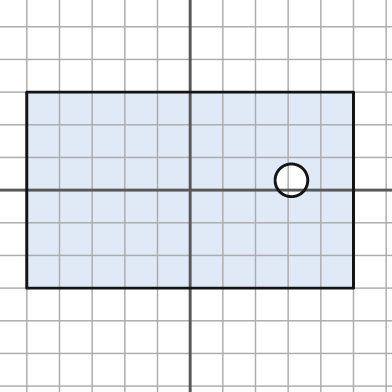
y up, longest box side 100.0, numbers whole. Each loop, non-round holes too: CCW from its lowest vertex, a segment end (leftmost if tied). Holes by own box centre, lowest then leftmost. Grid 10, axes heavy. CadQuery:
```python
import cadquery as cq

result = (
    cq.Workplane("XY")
    .moveTo(-50.0, -30.0)
    .lineTo(50.0, -30.0)
    .lineTo(50.0, 30.0)
    .lineTo(-50.0, 30.0)
    .close()
    .moveTo(31.0, 3.0)
    .circle(5.0)
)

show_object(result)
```